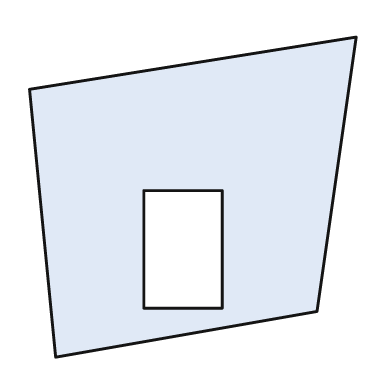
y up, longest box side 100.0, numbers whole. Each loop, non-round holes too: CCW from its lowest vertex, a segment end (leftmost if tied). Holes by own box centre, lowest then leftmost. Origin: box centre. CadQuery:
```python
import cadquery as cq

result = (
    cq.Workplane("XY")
    .moveTo(-42.0, -49.0)
    .lineTo(38.0, -35.0)
    .lineTo(50.0, 49.0)
    .lineTo(-50.0, 33.0)
    .close()
    .moveTo(-15.0, -34.0)
    .lineTo(9.0, -34.0)
    .lineTo(9.0, 2.0)
    .lineTo(-15.0, 2.0)
    .close()
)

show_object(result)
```